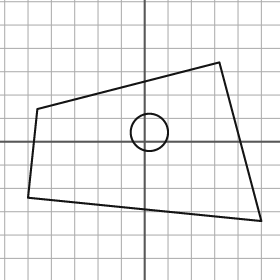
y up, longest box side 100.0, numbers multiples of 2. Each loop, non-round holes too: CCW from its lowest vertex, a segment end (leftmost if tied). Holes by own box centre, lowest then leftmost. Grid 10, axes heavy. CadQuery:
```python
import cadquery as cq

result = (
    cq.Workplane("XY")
    .moveTo(50.0, -34.0)
    .lineTo(32.0, 34.0)
    .lineTo(-46.0, 14.0)
    .lineTo(-50.0, -24.0)
    .close()
    .moveTo(2.0, 4.0)
    .circle(8.0)
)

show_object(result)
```